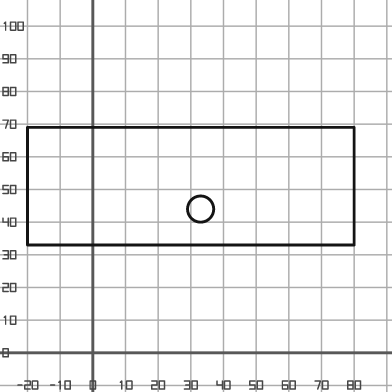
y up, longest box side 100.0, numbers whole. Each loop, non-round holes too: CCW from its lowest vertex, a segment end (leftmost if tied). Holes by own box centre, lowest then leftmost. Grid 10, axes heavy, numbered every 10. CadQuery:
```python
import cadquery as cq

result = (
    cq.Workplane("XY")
    .moveTo(-20.0, 33.0)
    .lineTo(80.0, 33.0)
    .lineTo(80.0, 69.0)
    .lineTo(-20.0, 69.0)
    .close()
    .moveTo(33.0, 44.0)
    .circle(4.0)
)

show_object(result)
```